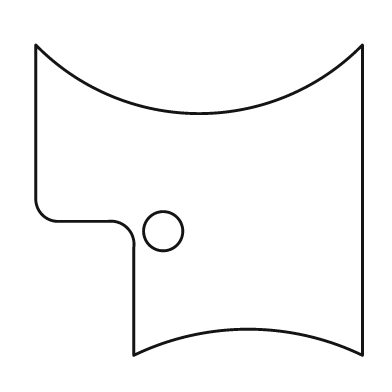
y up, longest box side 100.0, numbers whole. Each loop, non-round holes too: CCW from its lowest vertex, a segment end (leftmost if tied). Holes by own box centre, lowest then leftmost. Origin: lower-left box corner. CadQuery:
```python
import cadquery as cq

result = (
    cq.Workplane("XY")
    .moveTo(30.0, 0.0)
    .threePointArc((65.0, 8.0), (100.0, 0.0))
    .lineTo(100.0, 95.0)
    .threePointArc((50.0, 74.0), (0.0, 95.0))
    .lineTo(0.0, 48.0)
    .threePointArc((2.0, 43.0), (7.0, 41.0))
    .lineTo(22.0, 41.0)
    .threePointArc((28.0, 39.0), (30.0, 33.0))
    .close()
    .moveTo(39.0, 38.0)
    .circle(6.0)
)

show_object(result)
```